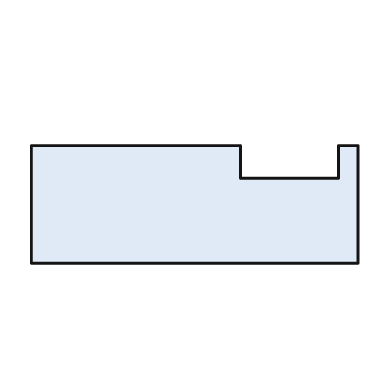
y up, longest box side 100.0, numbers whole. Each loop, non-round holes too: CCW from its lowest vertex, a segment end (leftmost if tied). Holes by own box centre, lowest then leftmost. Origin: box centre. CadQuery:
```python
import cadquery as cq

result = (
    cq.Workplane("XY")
    .moveTo(-50.0, -18.0)
    .lineTo(50.0, -18.0)
    .lineTo(50.0, 18.0)
    .lineTo(44.0, 18.0)
    .lineTo(44.0, 8.0)
    .lineTo(14.0, 8.0)
    .lineTo(14.0, 18.0)
    .lineTo(-50.0, 18.0)
    .close()
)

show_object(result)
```